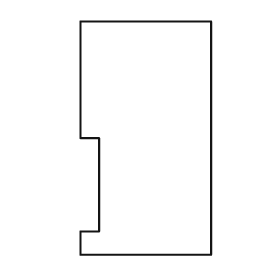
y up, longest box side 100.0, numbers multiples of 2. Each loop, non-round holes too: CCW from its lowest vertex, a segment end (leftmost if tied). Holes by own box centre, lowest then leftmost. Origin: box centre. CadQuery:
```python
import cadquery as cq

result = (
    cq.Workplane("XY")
    .moveTo(-28.0, -50.0)
    .lineTo(28.0, -50.0)
    .lineTo(28.0, 50.0)
    .lineTo(-28.0, 50.0)
    .lineTo(-28.0, 0.0)
    .lineTo(-20.0, 0.0)
    .lineTo(-20.0, -40.0)
    .lineTo(-28.0, -40.0)
    .close()
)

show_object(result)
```